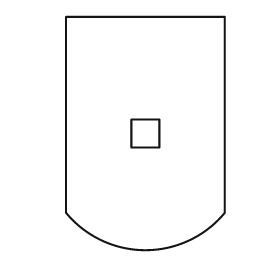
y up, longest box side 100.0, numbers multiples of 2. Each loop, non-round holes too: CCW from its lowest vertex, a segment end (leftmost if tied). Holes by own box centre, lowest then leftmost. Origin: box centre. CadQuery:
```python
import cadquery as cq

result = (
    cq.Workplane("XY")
    .moveTo(-34.0, -34.0)
    .threePointArc((0.0, -50.0), (34.0, -34.0))
    .lineTo(34.0, 50.0)
    .lineTo(-34.0, 50.0)
    .close()
    .moveTo(-6.0, -6.0)
    .lineTo(6.0, -6.0)
    .lineTo(6.0, 6.0)
    .lineTo(-6.0, 6.0)
    .close()
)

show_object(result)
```